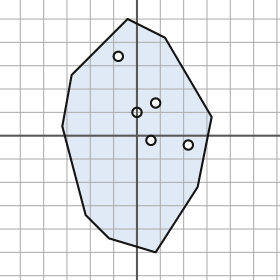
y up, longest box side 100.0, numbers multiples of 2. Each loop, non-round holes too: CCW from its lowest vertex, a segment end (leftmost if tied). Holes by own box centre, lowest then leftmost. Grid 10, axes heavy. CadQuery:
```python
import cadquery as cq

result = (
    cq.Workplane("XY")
    .moveTo(8.0, -50.0)
    .lineTo(26.0, -22.0)
    .lineTo(32.0, 8.0)
    .lineTo(12.0, 42.0)
    .lineTo(-4.0, 50.0)
    .lineTo(-28.0, 26.0)
    .lineTo(-32.0, 4.0)
    .lineTo(-22.0, -34.0)
    .lineTo(-12.0, -44.0)
    .close()
    .moveTo(22.0, -4.0)
    .circle(2.0)
    .moveTo(6.0, -2.0)
    .circle(2.0)
    .moveTo(0.0, 10.0)
    .circle(2.0)
    .moveTo(8.0, 14.0)
    .circle(2.0)
    .moveTo(-8.0, 34.0)
    .circle(2.0)
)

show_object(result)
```